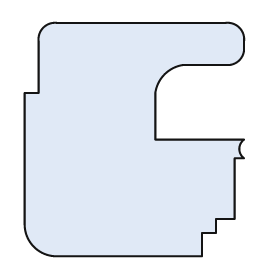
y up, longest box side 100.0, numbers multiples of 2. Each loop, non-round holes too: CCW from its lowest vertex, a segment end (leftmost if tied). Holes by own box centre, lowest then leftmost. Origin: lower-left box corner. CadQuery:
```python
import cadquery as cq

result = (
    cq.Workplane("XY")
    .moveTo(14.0, 0.0)
    .lineTo(76.0, 0.0)
    .lineTo(76.0, 10.0)
    .lineTo(82.0, 10.0)
    .lineTo(82.0, 16.0)
    .lineTo(90.0, 16.0)
    .lineTo(90.0, 42.0)
    .lineTo(94.0, 42.0)
    .threePointArc((92.0, 46.0), (94.0, 50.0))
    .lineTo(56.0, 50.0)
    .lineTo(56.0, 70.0)
    .threePointArc((60.0, 78.0), (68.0, 82.0))
    .lineTo(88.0, 82.0)
    .threePointArc((92.0, 84.0), (94.0, 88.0))
    .lineTo(94.0, 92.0)
    .threePointArc((92.0, 98.0), (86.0, 100.0))
    .lineTo(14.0, 100.0)
    .threePointArc((8.0, 98.0), (6.0, 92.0))
    .lineTo(6.0, 70.0)
    .lineTo(0.0, 70.0)
    .lineTo(0.0, 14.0)
    .threePointArc((4.0, 4.0), (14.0, 0.0))
    .close()
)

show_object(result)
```